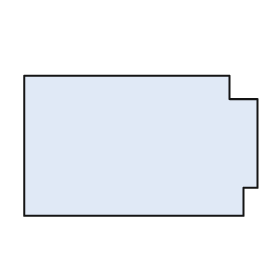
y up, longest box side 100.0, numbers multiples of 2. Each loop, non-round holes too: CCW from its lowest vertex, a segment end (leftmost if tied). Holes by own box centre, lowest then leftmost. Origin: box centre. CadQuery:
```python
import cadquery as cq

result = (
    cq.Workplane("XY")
    .moveTo(-50.0, -30.0)
    .lineTo(44.0, -30.0)
    .lineTo(44.0, -18.0)
    .lineTo(50.0, -18.0)
    .lineTo(50.0, 20.0)
    .lineTo(38.0, 20.0)
    .lineTo(38.0, 30.0)
    .lineTo(-50.0, 30.0)
    .close()
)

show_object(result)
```